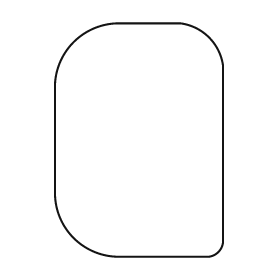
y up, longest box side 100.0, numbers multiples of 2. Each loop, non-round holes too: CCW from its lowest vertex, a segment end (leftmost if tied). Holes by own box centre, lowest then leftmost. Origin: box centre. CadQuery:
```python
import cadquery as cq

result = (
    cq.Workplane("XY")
    .moveTo(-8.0, -50.0)
    .lineTo(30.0, -50.0)
    .threePointArc((34.0, -48.0), (36.0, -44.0))
    .lineTo(36.0, 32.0)
    .threePointArc((30.0, 44.0), (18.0, 50.0))
    .lineTo(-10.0, 50.0)
    .threePointArc((-28.0, 42.0), (-36.0, 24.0))
    .lineTo(-36.0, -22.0)
    .threePointArc((-28.0, -42.0), (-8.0, -50.0))
    .close()
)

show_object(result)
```